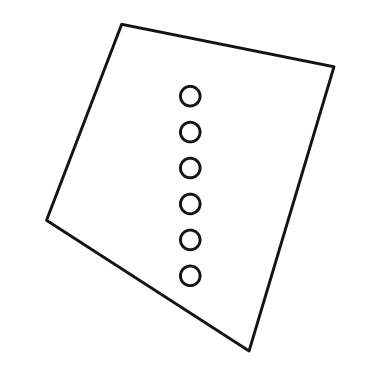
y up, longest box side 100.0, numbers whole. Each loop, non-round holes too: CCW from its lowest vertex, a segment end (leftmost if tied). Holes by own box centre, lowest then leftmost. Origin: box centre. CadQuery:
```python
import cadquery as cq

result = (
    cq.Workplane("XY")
    .moveTo(18.0, -50.0)
    .lineTo(44.0, 37.0)
    .lineTo(-21.0, 50.0)
    .lineTo(-44.0, -10.0)
    .close()
    .moveTo(0.0, -27.0)
    .circle(3.0)
    .moveTo(0.0, -16.0)
    .circle(3.0)
    .moveTo(0.0, -5.0)
    .circle(3.0)
    .moveTo(0.0, 6.0)
    .circle(3.0)
    .moveTo(0.0, 17.0)
    .circle(3.0)
    .moveTo(0.0, 28.0)
    .circle(3.0)
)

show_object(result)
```